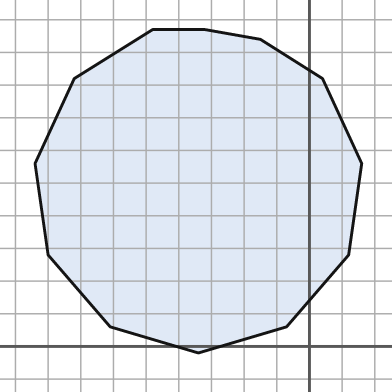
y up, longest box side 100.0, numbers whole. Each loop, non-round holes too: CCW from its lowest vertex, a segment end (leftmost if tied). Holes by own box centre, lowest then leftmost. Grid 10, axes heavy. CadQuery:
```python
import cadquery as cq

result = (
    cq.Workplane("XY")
    .moveTo(-34.0, -2.0)
    .lineTo(-7.0, 6.0)
    .lineTo(12.0, 28.0)
    .lineTo(16.0, 56.0)
    .lineTo(4.0, 82.0)
    .lineTo(-15.0, 94.0)
    .lineTo(-32.0, 97.0)
    .lineTo(-48.0, 97.0)
    .lineTo(-72.0, 82.0)
    .lineTo(-84.0, 56.0)
    .lineTo(-80.0, 28.0)
    .lineTo(-61.0, 6.0)
    .close()
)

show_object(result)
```